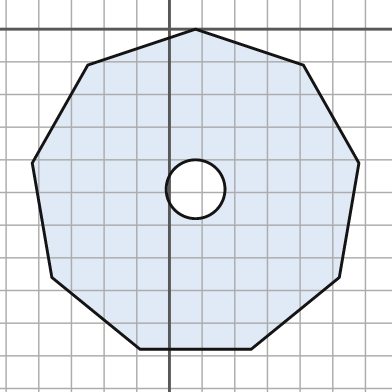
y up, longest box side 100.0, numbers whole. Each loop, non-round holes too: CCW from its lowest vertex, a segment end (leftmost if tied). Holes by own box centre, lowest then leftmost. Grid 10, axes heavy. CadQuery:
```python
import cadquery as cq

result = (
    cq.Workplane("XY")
    .moveTo(-9.0, -98.0)
    .lineTo(25.0, -98.0)
    .lineTo(52.0, -76.0)
    .lineTo(58.0, -41.0)
    .lineTo(41.0, -11.0)
    .lineTo(8.0, 0.0)
    .lineTo(-25.0, -11.0)
    .lineTo(-42.0, -41.0)
    .lineTo(-36.0, -76.0)
    .close()
    .moveTo(8.0, -49.0)
    .circle(9.0)
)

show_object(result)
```